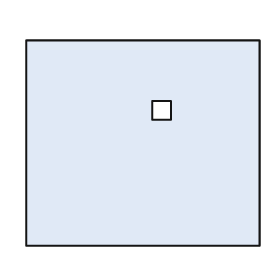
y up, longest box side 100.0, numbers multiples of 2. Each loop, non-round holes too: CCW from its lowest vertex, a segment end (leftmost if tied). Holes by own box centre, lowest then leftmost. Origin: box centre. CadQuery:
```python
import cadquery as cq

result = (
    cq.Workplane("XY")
    .moveTo(-50.0, -44.0)
    .lineTo(50.0, -44.0)
    .lineTo(50.0, 44.0)
    .lineTo(-50.0, 44.0)
    .close()
    .moveTo(4.0, 10.0)
    .lineTo(12.0, 10.0)
    .lineTo(12.0, 18.0)
    .lineTo(4.0, 18.0)
    .close()
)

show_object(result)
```